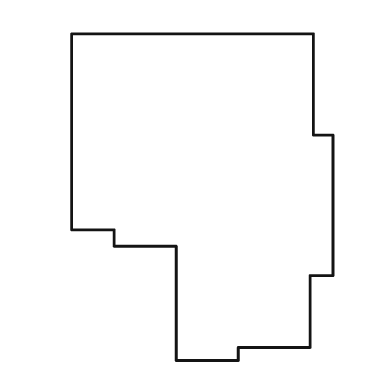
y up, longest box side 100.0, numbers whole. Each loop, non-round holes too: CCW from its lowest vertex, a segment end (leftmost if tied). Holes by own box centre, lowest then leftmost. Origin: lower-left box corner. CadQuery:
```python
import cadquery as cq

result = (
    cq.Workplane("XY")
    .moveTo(32.0, 0.0)
    .lineTo(51.0, 0.0)
    .lineTo(51.0, 4.0)
    .lineTo(73.0, 4.0)
    .lineTo(73.0, 26.0)
    .lineTo(80.0, 26.0)
    .lineTo(80.0, 69.0)
    .lineTo(74.0, 69.0)
    .lineTo(74.0, 100.0)
    .lineTo(0.0, 100.0)
    .lineTo(0.0, 40.0)
    .lineTo(13.0, 40.0)
    .lineTo(13.0, 35.0)
    .lineTo(32.0, 35.0)
    .close()
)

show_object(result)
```